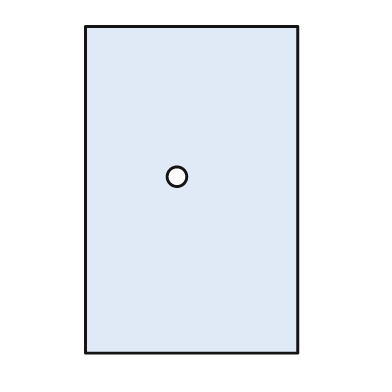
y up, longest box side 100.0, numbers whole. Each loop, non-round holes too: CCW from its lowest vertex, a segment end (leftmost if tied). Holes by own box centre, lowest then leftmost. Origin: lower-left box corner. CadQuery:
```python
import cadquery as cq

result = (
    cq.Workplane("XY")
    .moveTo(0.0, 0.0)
    .lineTo(65.0, 0.0)
    .lineTo(65.0, 100.0)
    .lineTo(0.0, 100.0)
    .close()
    .moveTo(28.0, 54.0)
    .circle(3.0)
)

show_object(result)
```